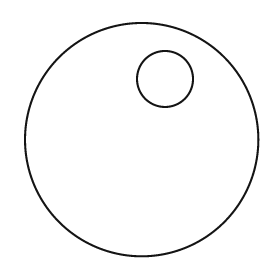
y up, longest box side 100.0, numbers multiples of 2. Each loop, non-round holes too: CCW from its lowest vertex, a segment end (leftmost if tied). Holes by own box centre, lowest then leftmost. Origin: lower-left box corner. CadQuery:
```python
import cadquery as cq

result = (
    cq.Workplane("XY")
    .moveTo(50.0, 50.0)
    .circle(50.0)
    .moveTo(60.0, 76.0)
    .circle(12.0)
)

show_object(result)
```